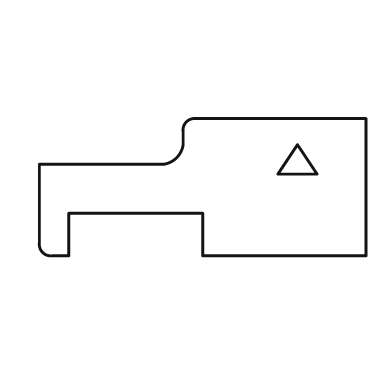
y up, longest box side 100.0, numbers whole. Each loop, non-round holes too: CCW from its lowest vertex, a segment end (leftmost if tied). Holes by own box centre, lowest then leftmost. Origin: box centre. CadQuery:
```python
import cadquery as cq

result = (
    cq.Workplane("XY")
    .moveTo(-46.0, -21.0)
    .lineTo(-41.0, -21.0)
    .lineTo(-41.0, -8.0)
    .lineTo(0.0, -8.0)
    .lineTo(0.0, -21.0)
    .lineTo(50.0, -21.0)
    .lineTo(50.0, 21.0)
    .lineTo(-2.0, 21.0)
    .threePointArc((-5.0, 20.0), (-6.0, 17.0))
    .lineTo(-6.0, 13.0)
    .threePointArc((-8.0, 9.0), (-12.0, 7.0))
    .lineTo(-50.0, 7.0)
    .lineTo(-50.0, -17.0)
    .threePointArc((-49.0, -20.0), (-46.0, -21.0))
    .close()
    .moveTo(23.0, 4.0)
    .lineTo(35.0, 4.0)
    .lineTo(29.0, 13.0)
    .close()
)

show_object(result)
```